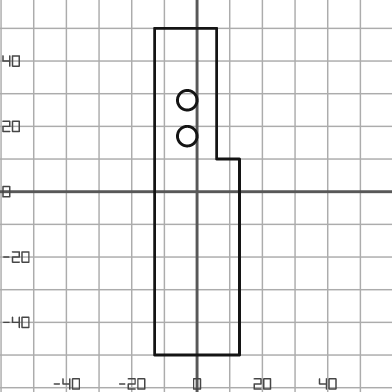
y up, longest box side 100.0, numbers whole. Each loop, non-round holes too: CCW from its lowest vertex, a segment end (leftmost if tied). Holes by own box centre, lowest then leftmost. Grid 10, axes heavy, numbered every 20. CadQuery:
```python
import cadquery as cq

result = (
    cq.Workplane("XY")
    .moveTo(-13.0, -50.0)
    .lineTo(13.0, -50.0)
    .lineTo(13.0, 10.0)
    .lineTo(6.0, 10.0)
    .lineTo(6.0, 50.0)
    .lineTo(-13.0, 50.0)
    .close()
    .moveTo(-3.0, 17.0)
    .circle(3.0)
    .moveTo(-3.0, 28.0)
    .circle(3.0)
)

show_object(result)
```